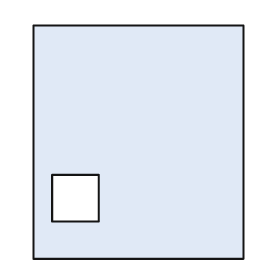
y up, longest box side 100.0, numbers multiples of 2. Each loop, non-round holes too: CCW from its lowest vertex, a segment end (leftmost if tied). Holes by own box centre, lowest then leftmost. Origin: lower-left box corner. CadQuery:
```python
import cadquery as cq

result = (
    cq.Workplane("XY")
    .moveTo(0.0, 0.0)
    .lineTo(90.0, 0.0)
    .lineTo(90.0, 100.0)
    .lineTo(0.0, 100.0)
    .close()
    .moveTo(8.0, 16.0)
    .lineTo(28.0, 16.0)
    .lineTo(28.0, 36.0)
    .lineTo(8.0, 36.0)
    .close()
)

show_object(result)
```